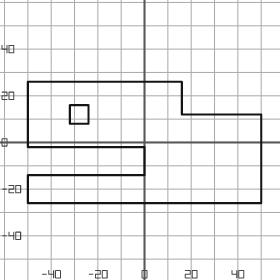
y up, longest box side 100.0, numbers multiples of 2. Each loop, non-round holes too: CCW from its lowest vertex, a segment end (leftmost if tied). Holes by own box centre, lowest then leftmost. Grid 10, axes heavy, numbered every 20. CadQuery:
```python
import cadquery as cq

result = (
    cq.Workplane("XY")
    .moveTo(-50.0, -26.0)
    .lineTo(50.0, -26.0)
    .lineTo(50.0, 12.0)
    .lineTo(16.0, 12.0)
    .lineTo(16.0, 26.0)
    .lineTo(-50.0, 26.0)
    .lineTo(-50.0, -2.0)
    .lineTo(0.0, -2.0)
    .lineTo(0.0, -14.0)
    .lineTo(-50.0, -14.0)
    .close()
    .moveTo(-32.0, 8.0)
    .lineTo(-24.0, 8.0)
    .lineTo(-24.0, 16.0)
    .lineTo(-32.0, 16.0)
    .close()
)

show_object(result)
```